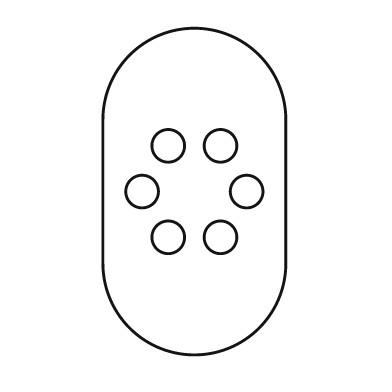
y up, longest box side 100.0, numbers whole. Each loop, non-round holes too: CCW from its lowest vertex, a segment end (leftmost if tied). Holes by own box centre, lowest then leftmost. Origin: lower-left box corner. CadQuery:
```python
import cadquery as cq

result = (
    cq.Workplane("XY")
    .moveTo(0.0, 28.0)
    .threePointArc((28.0, 0.0), (56.0, 28.0))
    .lineTo(56.0, 72.0)
    .threePointArc((28.0, 100.0), (0.0, 72.0))
    .close()
    .moveTo(20.0, 36.0)
    .circle(5.0)
    .moveTo(36.0, 36.0)
    .circle(5.0)
    .moveTo(12.0, 50.0)
    .circle(5.0)
    .moveTo(44.0, 50.0)
    .circle(5.0)
    .moveTo(20.0, 64.0)
    .circle(5.0)
    .moveTo(36.0, 64.0)
    .circle(5.0)
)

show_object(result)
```